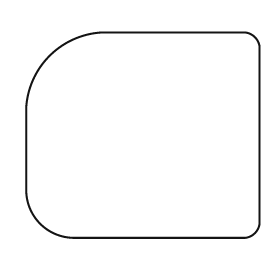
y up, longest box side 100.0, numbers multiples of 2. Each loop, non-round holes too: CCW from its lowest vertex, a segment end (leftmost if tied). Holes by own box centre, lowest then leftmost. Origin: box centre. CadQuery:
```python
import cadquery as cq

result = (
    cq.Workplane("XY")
    .moveTo(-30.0, -44.0)
    .lineTo(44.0, -44.0)
    .threePointArc((48.0, -42.0), (50.0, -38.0))
    .lineTo(50.0, 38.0)
    .threePointArc((48.0, 42.0), (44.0, 44.0))
    .lineTo(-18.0, 44.0)
    .threePointArc((-40.0, 34.0), (-50.0, 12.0))
    .lineTo(-50.0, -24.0)
    .threePointArc((-44.0, -38.0), (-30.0, -44.0))
    .close()
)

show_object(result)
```